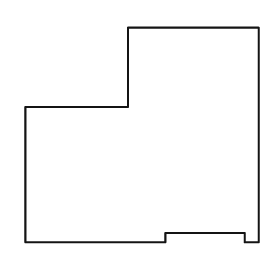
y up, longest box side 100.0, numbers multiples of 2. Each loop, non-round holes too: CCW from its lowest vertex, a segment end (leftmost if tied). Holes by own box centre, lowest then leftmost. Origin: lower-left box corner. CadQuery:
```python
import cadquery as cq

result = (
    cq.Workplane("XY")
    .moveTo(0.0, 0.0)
    .lineTo(60.0, 0.0)
    .lineTo(60.0, 4.0)
    .lineTo(94.0, 4.0)
    .lineTo(94.0, 0.0)
    .lineTo(100.0, 0.0)
    .lineTo(100.0, 92.0)
    .lineTo(44.0, 92.0)
    .lineTo(44.0, 58.0)
    .lineTo(0.0, 58.0)
    .close()
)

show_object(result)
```